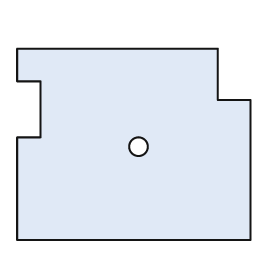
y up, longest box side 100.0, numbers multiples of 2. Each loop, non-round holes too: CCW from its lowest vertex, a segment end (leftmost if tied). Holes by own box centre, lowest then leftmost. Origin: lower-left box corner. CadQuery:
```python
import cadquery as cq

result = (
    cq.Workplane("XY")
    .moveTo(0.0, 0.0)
    .lineTo(100.0, 0.0)
    .lineTo(100.0, 60.0)
    .lineTo(86.0, 60.0)
    .lineTo(86.0, 82.0)
    .lineTo(0.0, 82.0)
    .lineTo(0.0, 68.0)
    .lineTo(10.0, 68.0)
    .lineTo(10.0, 44.0)
    .lineTo(0.0, 44.0)
    .close()
    .moveTo(52.0, 40.0)
    .circle(4.0)
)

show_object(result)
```